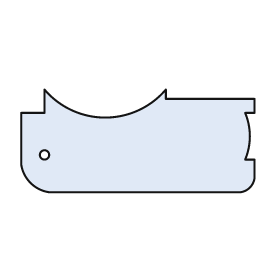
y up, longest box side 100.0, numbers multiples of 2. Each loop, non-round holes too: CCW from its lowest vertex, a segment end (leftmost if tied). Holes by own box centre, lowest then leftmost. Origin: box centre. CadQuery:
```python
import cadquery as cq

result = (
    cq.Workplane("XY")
    .moveTo(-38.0, -22.0)
    .lineTo(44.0, -22.0)
    .threePointArc((48.0, -20.0), (50.0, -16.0))
    .lineTo(50.0, -8.0)
    .lineTo(46.0, -8.0)
    .threePointArc((48.0, 2.0), (46.0, 12.0))
    .lineTo(50.0, 12.0)
    .lineTo(50.0, 18.0)
    .lineTo(12.0, 18.0)
    .lineTo(12.0, 22.0)
    .threePointArc((-14.0, 10.0), (-40.0, 22.0))
    .lineTo(-40.0, 12.0)
    .lineTo(-50.0, 12.0)
    .lineTo(-50.0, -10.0)
    .threePointArc((-46.0, -18.0), (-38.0, -22.0))
    .close()
    .moveTo(-40.0, -6.0)
    .circle(2.0)
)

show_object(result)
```